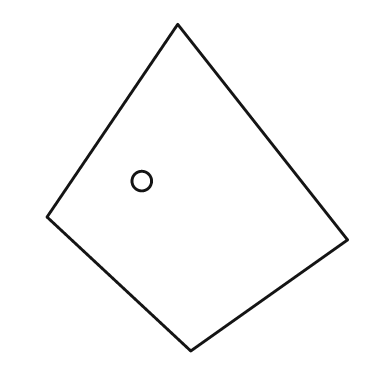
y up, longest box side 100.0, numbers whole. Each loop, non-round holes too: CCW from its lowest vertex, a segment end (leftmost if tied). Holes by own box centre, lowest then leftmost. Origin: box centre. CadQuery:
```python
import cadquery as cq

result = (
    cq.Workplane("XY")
    .moveTo(-2.0, -50.0)
    .lineTo(46.0, -16.0)
    .lineTo(-6.0, 50.0)
    .lineTo(-46.0, -9.0)
    .close()
    .moveTo(-17.0, 2.0)
    .circle(3.0)
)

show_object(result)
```